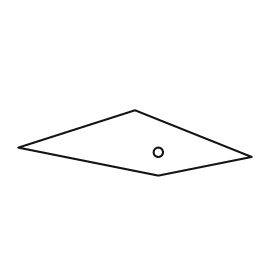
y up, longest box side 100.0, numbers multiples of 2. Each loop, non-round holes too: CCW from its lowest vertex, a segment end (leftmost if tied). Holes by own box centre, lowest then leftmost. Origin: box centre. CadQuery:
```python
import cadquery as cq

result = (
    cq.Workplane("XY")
    .moveTo(10.0, -14.0)
    .lineTo(50.0, -6.0)
    .lineTo(0.0, 14.0)
    .lineTo(-50.0, -2.0)
    .close()
    .moveTo(10.0, -4.0)
    .circle(2.0)
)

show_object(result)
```